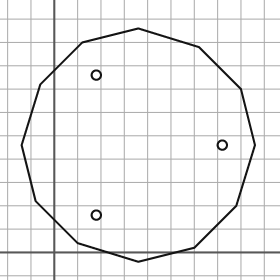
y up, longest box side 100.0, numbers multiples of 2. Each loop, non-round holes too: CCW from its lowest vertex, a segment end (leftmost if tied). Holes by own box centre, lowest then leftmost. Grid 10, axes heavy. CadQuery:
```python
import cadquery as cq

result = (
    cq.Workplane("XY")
    .moveTo(36.0, -4.0)
    .lineTo(60.0, 2.0)
    .lineTo(78.0, 20.0)
    .lineTo(86.0, 46.0)
    .lineTo(80.0, 70.0)
    .lineTo(62.0, 88.0)
    .lineTo(36.0, 96.0)
    .lineTo(12.0, 90.0)
    .lineTo(-6.0, 72.0)
    .lineTo(-14.0, 46.0)
    .lineTo(-8.0, 22.0)
    .lineTo(10.0, 4.0)
    .close()
    .moveTo(18.0, 16.0)
    .circle(2.0)
    .moveTo(72.0, 46.0)
    .circle(2.0)
    .moveTo(18.0, 76.0)
    .circle(2.0)
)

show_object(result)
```